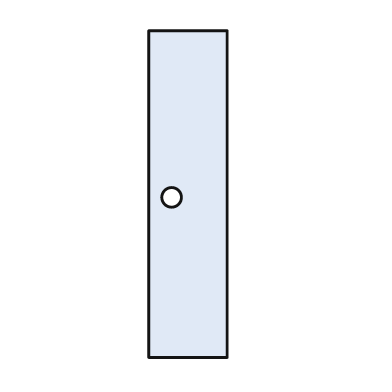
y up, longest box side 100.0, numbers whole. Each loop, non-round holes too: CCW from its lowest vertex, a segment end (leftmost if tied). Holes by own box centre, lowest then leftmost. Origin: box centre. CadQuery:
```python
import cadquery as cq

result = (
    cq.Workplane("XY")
    .moveTo(-12.0, -50.0)
    .lineTo(12.0, -50.0)
    .lineTo(12.0, 50.0)
    .lineTo(-12.0, 50.0)
    .close()
    .moveTo(-5.0, -1.0)
    .circle(3.0)
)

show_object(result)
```